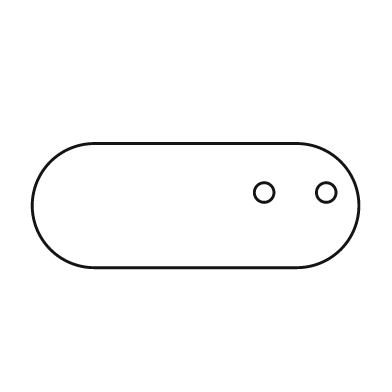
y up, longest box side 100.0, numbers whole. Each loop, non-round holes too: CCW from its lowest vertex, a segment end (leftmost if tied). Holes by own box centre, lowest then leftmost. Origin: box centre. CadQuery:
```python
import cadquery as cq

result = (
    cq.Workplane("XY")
    .moveTo(-31.0, -19.0)
    .lineTo(31.0, -19.0)
    .threePointArc((50.0, 0.0), (31.0, 19.0))
    .lineTo(-31.0, 19.0)
    .threePointArc((-50.0, 0.0), (-31.0, -19.0))
    .close()
    .moveTo(21.0, 4.0)
    .circle(3.0)
    .moveTo(40.0, 4.0)
    .circle(3.0)
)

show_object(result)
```